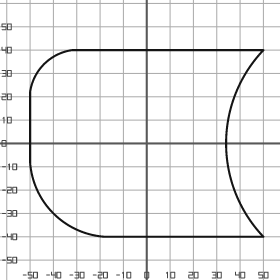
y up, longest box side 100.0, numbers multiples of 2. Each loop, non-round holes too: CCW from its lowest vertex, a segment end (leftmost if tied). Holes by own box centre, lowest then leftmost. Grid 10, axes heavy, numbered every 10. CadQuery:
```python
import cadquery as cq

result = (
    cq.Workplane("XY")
    .moveTo(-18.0, -40.0)
    .lineTo(50.0, -40.0)
    .threePointArc((34.0, 0.0), (50.0, 40.0))
    .lineTo(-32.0, 40.0)
    .threePointArc((-44.0, 34.0), (-50.0, 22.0))
    .lineTo(-50.0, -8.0)
    .threePointArc((-40.0, -30.0), (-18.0, -40.0))
    .close()
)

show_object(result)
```